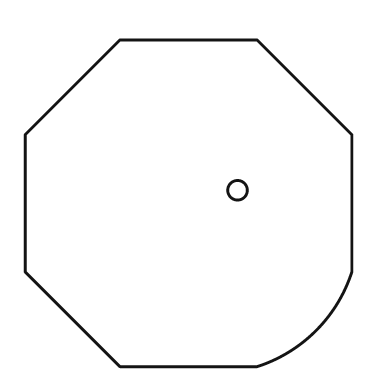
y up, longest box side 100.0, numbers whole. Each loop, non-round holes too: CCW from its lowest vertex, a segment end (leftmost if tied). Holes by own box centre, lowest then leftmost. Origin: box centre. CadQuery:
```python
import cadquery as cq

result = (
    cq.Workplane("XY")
    .moveTo(-21.0, -50.0)
    .lineTo(21.0, -50.0)
    .threePointArc((39.0, -39.0), (50.0, -21.0))
    .lineTo(50.0, 21.0)
    .lineTo(21.0, 50.0)
    .lineTo(-21.0, 50.0)
    .lineTo(-50.0, 21.0)
    .lineTo(-50.0, -21.0)
    .close()
    .moveTo(15.0, 4.0)
    .circle(3.0)
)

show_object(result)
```